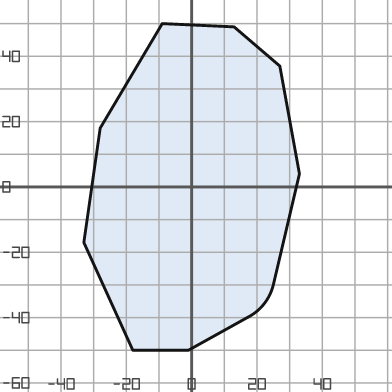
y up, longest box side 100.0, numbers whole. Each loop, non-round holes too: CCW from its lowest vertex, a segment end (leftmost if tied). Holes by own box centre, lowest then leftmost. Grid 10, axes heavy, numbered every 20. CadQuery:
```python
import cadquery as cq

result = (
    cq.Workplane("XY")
    .moveTo(-18.0, -50.0)
    .lineTo(-1.0, -50.0)
    .lineTo(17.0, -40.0)
    .threePointArc((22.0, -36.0), (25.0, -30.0))
    .lineTo(33.0, 4.0)
    .lineTo(27.0, 37.0)
    .lineTo(13.0, 49.0)
    .lineTo(-9.0, 50.0)
    .lineTo(-28.0, 18.0)
    .lineTo(-33.0, -17.0)
    .close()
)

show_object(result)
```